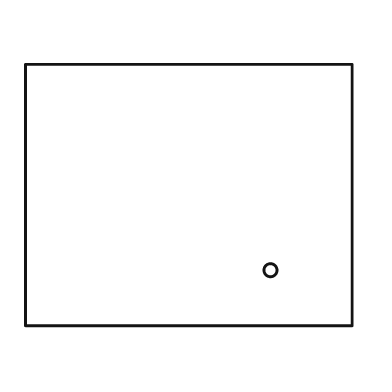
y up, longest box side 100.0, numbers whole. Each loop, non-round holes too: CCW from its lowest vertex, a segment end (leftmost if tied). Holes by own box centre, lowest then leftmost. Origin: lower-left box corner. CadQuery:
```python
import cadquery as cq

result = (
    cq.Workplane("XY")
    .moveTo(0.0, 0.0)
    .lineTo(100.0, 0.0)
    .lineTo(100.0, 80.0)
    .lineTo(0.0, 80.0)
    .close()
    .moveTo(75.0, 17.0)
    .circle(2.0)
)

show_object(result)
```